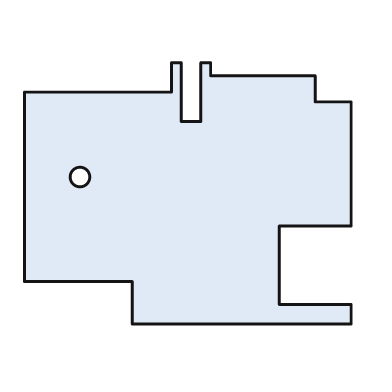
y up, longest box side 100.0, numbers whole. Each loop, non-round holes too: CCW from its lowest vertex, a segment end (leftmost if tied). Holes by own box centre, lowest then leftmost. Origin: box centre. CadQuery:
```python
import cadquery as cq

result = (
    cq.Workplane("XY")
    .moveTo(-17.0, -40.0)
    .lineTo(50.0, -40.0)
    .lineTo(50.0, -34.0)
    .lineTo(28.0, -34.0)
    .lineTo(28.0, -10.0)
    .lineTo(50.0, -10.0)
    .lineTo(50.0, 28.0)
    .lineTo(39.0, 28.0)
    .lineTo(39.0, 36.0)
    .lineTo(7.0, 36.0)
    .lineTo(7.0, 40.0)
    .lineTo(4.0, 40.0)
    .lineTo(4.0, 22.0)
    .lineTo(-2.0, 22.0)
    .lineTo(-2.0, 40.0)
    .lineTo(-5.0, 40.0)
    .lineTo(-5.0, 31.0)
    .lineTo(-50.0, 31.0)
    .lineTo(-50.0, -27.0)
    .lineTo(-17.0, -27.0)
    .close()
    .moveTo(-33.0, 5.0)
    .circle(3.0)
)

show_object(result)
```